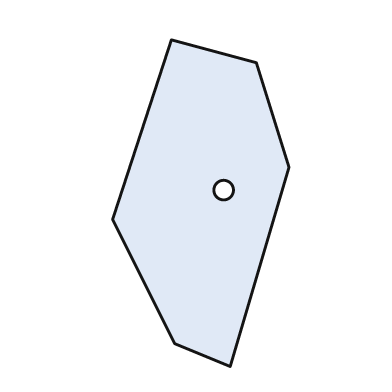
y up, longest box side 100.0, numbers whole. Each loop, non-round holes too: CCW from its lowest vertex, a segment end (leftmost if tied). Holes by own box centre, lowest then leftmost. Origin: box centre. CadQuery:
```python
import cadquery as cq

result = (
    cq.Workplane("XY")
    .moveTo(9.0, -50.0)
    .lineTo(27.0, 11.0)
    .lineTo(17.0, 43.0)
    .lineTo(-9.0, 50.0)
    .lineTo(-27.0, -5.0)
    .lineTo(-8.0, -43.0)
    .close()
    .moveTo(7.0, 4.0)
    .circle(3.0)
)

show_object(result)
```